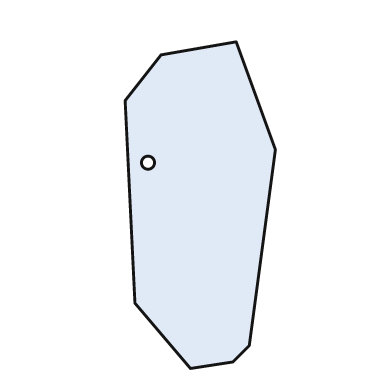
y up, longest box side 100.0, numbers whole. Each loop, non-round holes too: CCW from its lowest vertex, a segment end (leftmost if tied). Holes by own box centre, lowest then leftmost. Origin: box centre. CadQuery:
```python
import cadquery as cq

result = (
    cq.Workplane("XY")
    .moveTo(-3.0, -50.0)
    .lineTo(10.0, -48.0)
    .lineTo(15.0, -43.0)
    .lineTo(23.0, 17.0)
    .lineTo(11.0, 50.0)
    .lineTo(-12.0, 46.0)
    .lineTo(-23.0, 32.0)
    .lineTo(-20.0, -30.0)
    .close()
    .moveTo(-16.0, 13.0)
    .circle(2.0)
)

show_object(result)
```